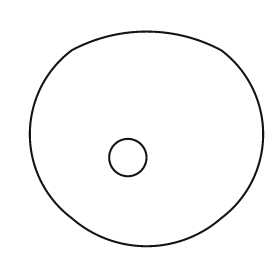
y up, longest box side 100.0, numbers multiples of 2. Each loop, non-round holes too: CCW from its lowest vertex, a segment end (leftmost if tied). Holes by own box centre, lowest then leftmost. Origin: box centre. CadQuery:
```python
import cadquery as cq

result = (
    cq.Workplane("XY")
    .moveTo(-32.0, -34.0)
    .threePointArc((0.0, -46.0), (32.0, -34.0))
    .threePointArc((50.0, 2.0), (32.0, 38.0))
    .threePointArc((0.0, 46.0), (-32.0, 38.0))
    .threePointArc((-50.0, 2.0), (-32.0, -34.0))
    .close()
    .moveTo(-8.0, -8.0)
    .circle(8.0)
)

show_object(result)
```